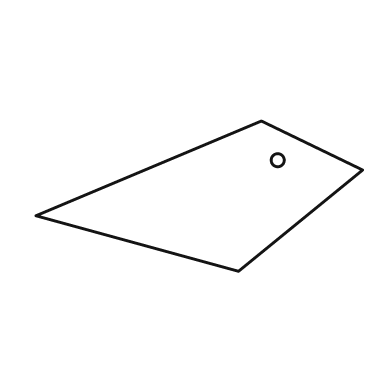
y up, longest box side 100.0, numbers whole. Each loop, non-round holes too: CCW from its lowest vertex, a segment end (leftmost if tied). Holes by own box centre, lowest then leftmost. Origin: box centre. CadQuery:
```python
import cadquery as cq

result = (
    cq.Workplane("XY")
    .moveTo(12.0, -23.0)
    .lineTo(50.0, 8.0)
    .lineTo(19.0, 23.0)
    .lineTo(-50.0, -6.0)
    .close()
    .moveTo(24.0, 11.0)
    .circle(2.0)
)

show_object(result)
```